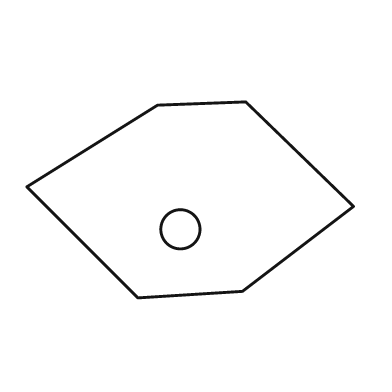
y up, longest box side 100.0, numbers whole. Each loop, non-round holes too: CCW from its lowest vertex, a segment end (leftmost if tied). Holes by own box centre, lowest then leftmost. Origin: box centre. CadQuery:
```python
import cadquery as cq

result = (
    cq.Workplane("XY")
    .moveTo(-16.0, -30.0)
    .lineTo(16.0, -28.0)
    .lineTo(50.0, -2.0)
    .lineTo(17.0, 30.0)
    .lineTo(-10.0, 29.0)
    .lineTo(-50.0, 4.0)
    .close()
    .moveTo(-3.0, -9.0)
    .circle(6.0)
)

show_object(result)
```